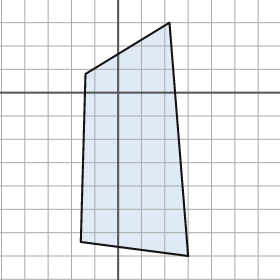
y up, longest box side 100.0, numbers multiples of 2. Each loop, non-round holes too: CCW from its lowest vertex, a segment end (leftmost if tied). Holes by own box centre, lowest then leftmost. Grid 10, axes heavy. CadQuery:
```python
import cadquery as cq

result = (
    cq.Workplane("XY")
    .moveTo(30.0, -70.0)
    .lineTo(22.0, 30.0)
    .lineTo(-14.0, 8.0)
    .lineTo(-16.0, -64.0)
    .close()
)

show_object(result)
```